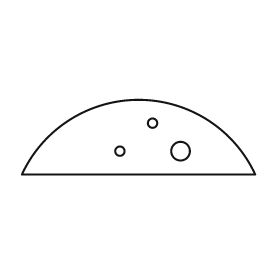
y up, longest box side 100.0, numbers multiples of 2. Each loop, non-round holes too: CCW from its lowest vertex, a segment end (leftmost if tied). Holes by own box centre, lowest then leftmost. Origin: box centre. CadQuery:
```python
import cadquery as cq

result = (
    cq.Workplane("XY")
    .moveTo(-50.0, -16.0)
    .lineTo(50.0, -16.0)
    .threePointArc((0.0, 16.0), (-50.0, -16.0))
    .close()
    .moveTo(-8.0, -6.0)
    .circle(2.0)
    .moveTo(18.0, -6.0)
    .circle(4.0)
    .moveTo(6.0, 6.0)
    .circle(2.0)
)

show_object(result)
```